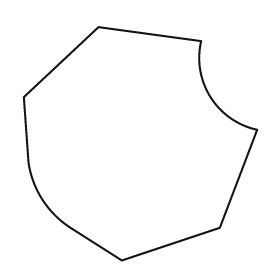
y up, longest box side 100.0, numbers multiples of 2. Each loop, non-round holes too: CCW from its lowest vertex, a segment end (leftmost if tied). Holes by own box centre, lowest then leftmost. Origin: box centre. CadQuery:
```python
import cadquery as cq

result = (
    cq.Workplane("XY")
    .moveTo(-8.0, -50.0)
    .lineTo(34.0, -36.0)
    .lineTo(50.0, 6.0)
    .threePointArc((30.0, 20.0), (26.0, 44.0))
    .lineTo(-18.0, 50.0)
    .lineTo(-50.0, 20.0)
    .lineTo(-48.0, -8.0)
    .threePointArc((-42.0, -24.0), (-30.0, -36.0))
    .close()
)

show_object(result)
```